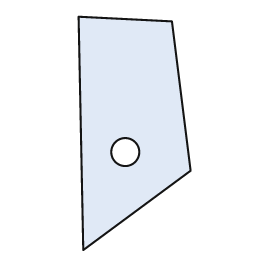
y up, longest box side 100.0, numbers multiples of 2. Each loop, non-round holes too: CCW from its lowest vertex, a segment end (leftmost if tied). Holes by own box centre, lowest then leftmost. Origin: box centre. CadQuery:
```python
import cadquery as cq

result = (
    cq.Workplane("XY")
    .moveTo(-22.0, -50.0)
    .lineTo(24.0, -16.0)
    .lineTo(16.0, 48.0)
    .lineTo(-24.0, 50.0)
    .close()
    .moveTo(-4.0, -8.0)
    .circle(6.0)
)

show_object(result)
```